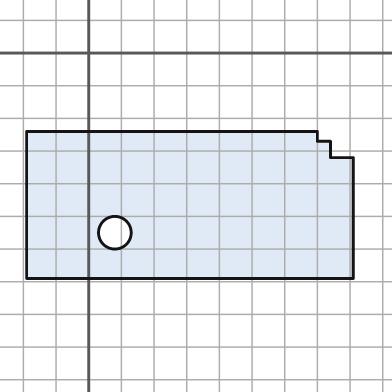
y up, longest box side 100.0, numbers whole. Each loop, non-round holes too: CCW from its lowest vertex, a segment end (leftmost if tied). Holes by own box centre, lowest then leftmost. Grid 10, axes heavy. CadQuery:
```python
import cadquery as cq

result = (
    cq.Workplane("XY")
    .moveTo(-19.0, -69.0)
    .lineTo(81.0, -69.0)
    .lineTo(81.0, -32.0)
    .lineTo(74.0, -32.0)
    .lineTo(74.0, -27.0)
    .lineTo(70.0, -27.0)
    .lineTo(70.0, -24.0)
    .lineTo(-19.0, -24.0)
    .close()
    .moveTo(8.0, -55.0)
    .circle(5.0)
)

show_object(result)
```